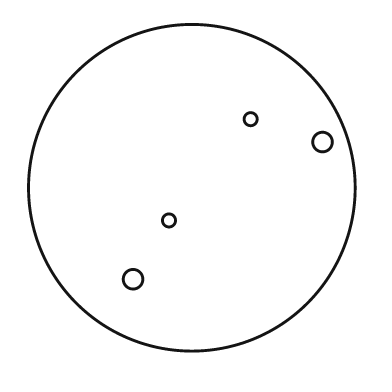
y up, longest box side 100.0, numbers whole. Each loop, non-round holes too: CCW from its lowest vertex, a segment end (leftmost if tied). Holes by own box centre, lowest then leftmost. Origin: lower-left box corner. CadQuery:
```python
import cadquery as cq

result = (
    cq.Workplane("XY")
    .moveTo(50.0, 50.0)
    .circle(50.0)
    .moveTo(32.0, 22.0)
    .circle(3.0)
    .moveTo(43.0, 40.0)
    .circle(2.0)
    .moveTo(90.0, 64.0)
    .circle(3.0)
    .moveTo(68.0, 71.0)
    .circle(2.0)
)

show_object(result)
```